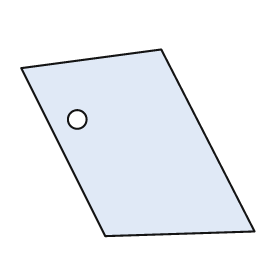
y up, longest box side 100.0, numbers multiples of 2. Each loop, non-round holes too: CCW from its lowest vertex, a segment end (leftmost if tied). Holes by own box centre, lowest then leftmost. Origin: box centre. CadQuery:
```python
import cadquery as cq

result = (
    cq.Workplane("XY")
    .moveTo(-14.0, -40.0)
    .lineTo(50.0, -38.0)
    .lineTo(10.0, 40.0)
    .lineTo(-50.0, 32.0)
    .close()
    .moveTo(-26.0, 10.0)
    .circle(4.0)
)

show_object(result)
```